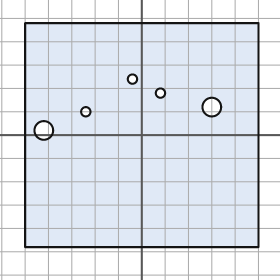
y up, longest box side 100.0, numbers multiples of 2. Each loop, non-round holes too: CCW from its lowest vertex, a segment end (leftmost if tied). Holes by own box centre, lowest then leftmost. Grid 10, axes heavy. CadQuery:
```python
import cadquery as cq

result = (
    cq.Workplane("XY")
    .moveTo(-50.0, -48.0)
    .lineTo(50.0, -48.0)
    .lineTo(50.0, 48.0)
    .lineTo(-50.0, 48.0)
    .close()
    .moveTo(-42.0, 2.0)
    .circle(4.0)
    .moveTo(-24.0, 10.0)
    .circle(2.0)
    .moveTo(30.0, 12.0)
    .circle(4.0)
    .moveTo(8.0, 18.0)
    .circle(2.0)
    .moveTo(-4.0, 24.0)
    .circle(2.0)
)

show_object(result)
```